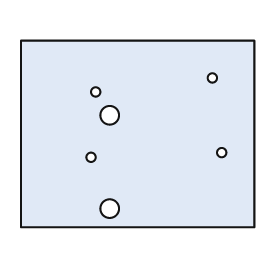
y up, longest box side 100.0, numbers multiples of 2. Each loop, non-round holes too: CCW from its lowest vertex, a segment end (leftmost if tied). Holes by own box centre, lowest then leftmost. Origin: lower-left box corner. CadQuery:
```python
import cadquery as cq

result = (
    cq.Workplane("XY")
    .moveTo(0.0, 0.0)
    .lineTo(100.0, 0.0)
    .lineTo(100.0, 80.0)
    .lineTo(0.0, 80.0)
    .close()
    .moveTo(38.0, 8.0)
    .circle(4.0)
    .moveTo(30.0, 30.0)
    .circle(2.0)
    .moveTo(86.0, 32.0)
    .circle(2.0)
    .moveTo(38.0, 48.0)
    .circle(4.0)
    .moveTo(32.0, 58.0)
    .circle(2.0)
    .moveTo(82.0, 64.0)
    .circle(2.0)
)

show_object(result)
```